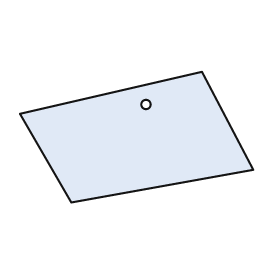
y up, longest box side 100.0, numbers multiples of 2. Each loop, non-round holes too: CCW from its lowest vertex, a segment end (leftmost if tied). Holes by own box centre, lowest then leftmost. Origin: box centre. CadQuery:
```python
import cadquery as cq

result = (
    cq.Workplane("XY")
    .moveTo(-28.0, -28.0)
    .lineTo(50.0, -14.0)
    .lineTo(28.0, 28.0)
    .lineTo(-50.0, 10.0)
    .close()
    .moveTo(4.0, 14.0)
    .circle(2.0)
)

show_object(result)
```